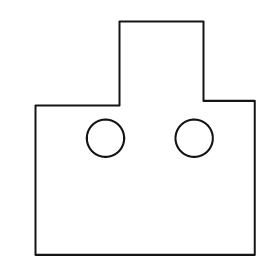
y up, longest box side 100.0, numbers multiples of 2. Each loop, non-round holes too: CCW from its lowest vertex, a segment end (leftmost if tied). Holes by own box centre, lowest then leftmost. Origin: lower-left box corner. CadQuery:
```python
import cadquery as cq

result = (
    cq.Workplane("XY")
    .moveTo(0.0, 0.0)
    .lineTo(94.0, 0.0)
    .lineTo(94.0, 66.0)
    .lineTo(72.0, 66.0)
    .lineTo(72.0, 100.0)
    .lineTo(36.0, 100.0)
    .lineTo(36.0, 64.0)
    .lineTo(0.0, 64.0)
    .close()
    .moveTo(30.0, 50.0)
    .circle(8.0)
    .moveTo(68.0, 50.0)
    .circle(8.0)
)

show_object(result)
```